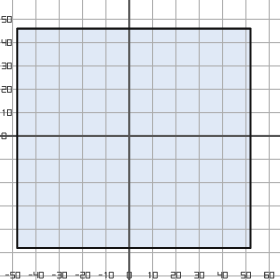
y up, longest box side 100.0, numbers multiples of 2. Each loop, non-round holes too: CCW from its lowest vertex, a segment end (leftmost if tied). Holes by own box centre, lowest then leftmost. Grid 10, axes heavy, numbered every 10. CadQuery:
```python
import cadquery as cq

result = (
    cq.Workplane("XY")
    .moveTo(-48.0, -48.0)
    .lineTo(52.0, -48.0)
    .lineTo(52.0, 46.0)
    .lineTo(-48.0, 46.0)
    .close()
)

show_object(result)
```